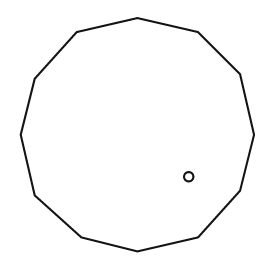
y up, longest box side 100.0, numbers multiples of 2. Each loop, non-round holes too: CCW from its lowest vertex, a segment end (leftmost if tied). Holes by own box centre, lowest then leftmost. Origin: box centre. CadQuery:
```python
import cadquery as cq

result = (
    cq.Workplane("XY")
    .moveTo(0.0, -50.0)
    .lineTo(26.0, -44.0)
    .lineTo(44.0, -24.0)
    .lineTo(50.0, 0.0)
    .lineTo(44.0, 26.0)
    .lineTo(26.0, 44.0)
    .lineTo(0.0, 50.0)
    .lineTo(-26.0, 44.0)
    .lineTo(-44.0, 24.0)
    .lineTo(-50.0, 0.0)
    .lineTo(-44.0, -26.0)
    .lineTo(-24.0, -44.0)
    .close()
    .moveTo(22.0, -18.0)
    .circle(2.0)
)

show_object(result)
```